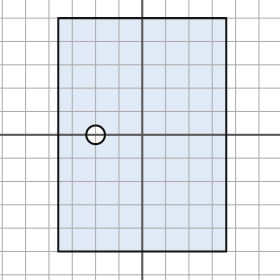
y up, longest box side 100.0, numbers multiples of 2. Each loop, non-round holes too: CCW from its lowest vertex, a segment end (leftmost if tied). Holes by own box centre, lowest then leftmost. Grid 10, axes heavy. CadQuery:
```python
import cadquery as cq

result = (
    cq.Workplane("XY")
    .moveTo(-36.0, -50.0)
    .lineTo(36.0, -50.0)
    .lineTo(36.0, 50.0)
    .lineTo(-36.0, 50.0)
    .close()
    .moveTo(-20.0, 0.0)
    .circle(4.0)
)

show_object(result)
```